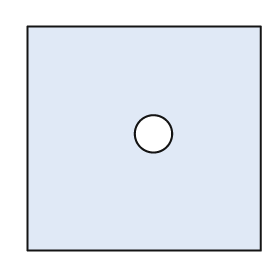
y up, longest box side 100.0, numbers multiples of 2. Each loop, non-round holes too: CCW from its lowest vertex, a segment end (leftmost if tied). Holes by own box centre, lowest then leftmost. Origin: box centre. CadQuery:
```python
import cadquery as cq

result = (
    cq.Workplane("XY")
    .moveTo(-50.0, -48.0)
    .lineTo(50.0, -48.0)
    .lineTo(50.0, 48.0)
    .lineTo(-50.0, 48.0)
    .close()
    .moveTo(4.0, 2.0)
    .circle(8.0)
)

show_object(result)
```